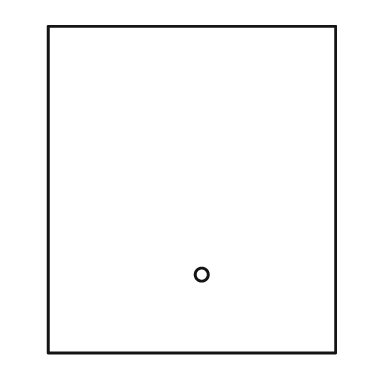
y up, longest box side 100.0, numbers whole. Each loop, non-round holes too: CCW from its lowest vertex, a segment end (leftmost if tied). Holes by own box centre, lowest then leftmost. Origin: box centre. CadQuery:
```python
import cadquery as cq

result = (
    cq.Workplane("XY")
    .moveTo(-44.0, -50.0)
    .lineTo(44.0, -50.0)
    .lineTo(44.0, 50.0)
    .lineTo(-44.0, 50.0)
    .close()
    .moveTo(3.0, -26.0)
    .circle(2.0)
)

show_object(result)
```